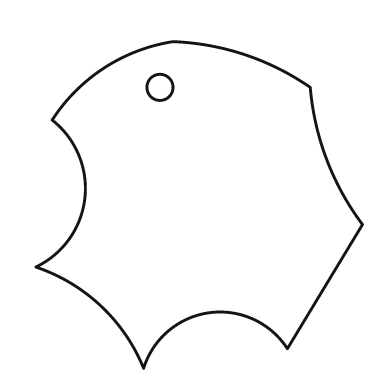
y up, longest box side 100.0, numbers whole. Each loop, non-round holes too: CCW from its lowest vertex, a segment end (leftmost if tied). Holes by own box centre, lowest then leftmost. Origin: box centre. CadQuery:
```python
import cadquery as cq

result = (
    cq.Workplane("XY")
    .moveTo(-17.0, -50.0)
    .threePointArc((3.0, -33.0), (27.0, -44.0))
    .lineTo(50.0, -6.0)
    .threePointArc((39.0, 14.0), (34.0, 36.0))
    .threePointArc((14.0, 46.0), (-8.0, 50.0))
    .threePointArc((-29.0, 42.0), (-45.0, 26.0))
    .threePointArc((-35.0, 2.0), (-50.0, -19.0))
    .threePointArc((-30.0, -31.0), (-17.0, -50.0))
    .close()
    .moveTo(-12.0, 36.0)
    .circle(4.0)
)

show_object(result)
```